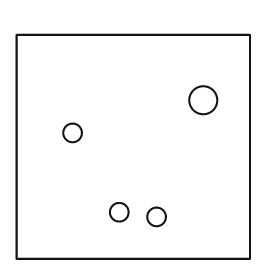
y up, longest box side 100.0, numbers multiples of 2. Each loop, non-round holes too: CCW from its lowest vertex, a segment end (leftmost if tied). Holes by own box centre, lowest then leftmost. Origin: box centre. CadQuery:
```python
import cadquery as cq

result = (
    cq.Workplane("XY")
    .moveTo(-50.0, -48.0)
    .lineTo(50.0, -48.0)
    .lineTo(50.0, 48.0)
    .lineTo(-50.0, 48.0)
    .close()
    .moveTo(10.0, -30.0)
    .circle(4.0)
    .moveTo(-6.0, -28.0)
    .circle(4.0)
    .moveTo(-26.0, 6.0)
    .circle(4.0)
    .moveTo(30.0, 20.0)
    .circle(6.0)
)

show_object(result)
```